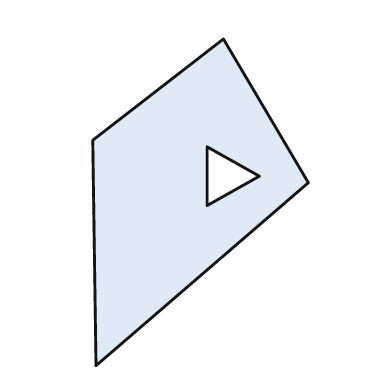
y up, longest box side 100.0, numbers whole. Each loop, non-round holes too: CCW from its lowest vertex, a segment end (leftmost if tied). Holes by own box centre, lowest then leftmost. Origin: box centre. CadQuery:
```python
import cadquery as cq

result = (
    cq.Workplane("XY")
    .moveTo(-32.0, -50.0)
    .lineTo(33.0, 6.0)
    .lineTo(7.0, 50.0)
    .lineTo(-33.0, 19.0)
    .close()
    .moveTo(2.0, -1.0)
    .lineTo(18.0, 8.0)
    .lineTo(2.0, 17.0)
    .close()
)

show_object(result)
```